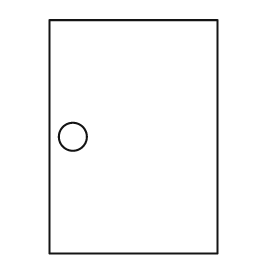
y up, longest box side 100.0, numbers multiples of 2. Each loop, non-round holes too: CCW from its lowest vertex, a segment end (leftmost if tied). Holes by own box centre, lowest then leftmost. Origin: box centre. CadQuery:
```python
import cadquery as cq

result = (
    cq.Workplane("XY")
    .moveTo(-36.0, -50.0)
    .lineTo(36.0, -50.0)
    .lineTo(36.0, 50.0)
    .lineTo(-36.0, 50.0)
    .close()
    .moveTo(-26.0, 0.0)
    .circle(6.0)
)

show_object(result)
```